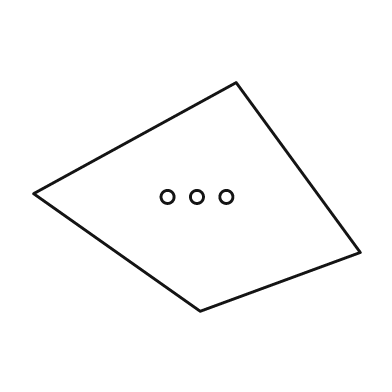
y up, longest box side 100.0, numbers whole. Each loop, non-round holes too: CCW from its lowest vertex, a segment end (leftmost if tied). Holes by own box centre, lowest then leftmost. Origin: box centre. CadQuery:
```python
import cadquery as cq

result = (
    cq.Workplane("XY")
    .moveTo(1.0, -35.0)
    .lineTo(50.0, -17.0)
    .lineTo(12.0, 35.0)
    .lineTo(-50.0, 1.0)
    .close()
    .moveTo(-9.0, 0.0)
    .circle(2.0)
    .moveTo(0.0, 0.0)
    .circle(2.0)
    .moveTo(9.0, 0.0)
    .circle(2.0)
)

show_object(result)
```